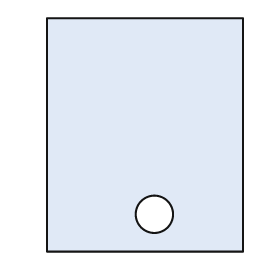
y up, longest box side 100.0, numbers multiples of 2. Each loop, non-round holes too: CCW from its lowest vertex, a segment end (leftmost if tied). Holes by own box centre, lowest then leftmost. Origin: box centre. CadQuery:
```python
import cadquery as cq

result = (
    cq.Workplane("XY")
    .moveTo(-42.0, -50.0)
    .lineTo(42.0, -50.0)
    .lineTo(42.0, 50.0)
    .lineTo(-42.0, 50.0)
    .close()
    .moveTo(4.0, -34.0)
    .circle(8.0)
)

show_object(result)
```